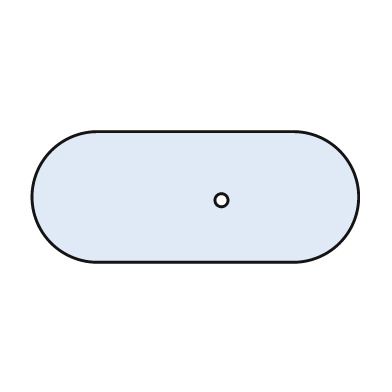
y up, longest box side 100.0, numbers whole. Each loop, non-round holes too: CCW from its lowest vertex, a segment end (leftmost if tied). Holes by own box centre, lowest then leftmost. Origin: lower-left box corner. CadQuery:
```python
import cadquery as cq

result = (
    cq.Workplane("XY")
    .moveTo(20.0, 0.0)
    .lineTo(80.0, 0.0)
    .threePointArc((100.0, 20.0), (80.0, 40.0))
    .lineTo(20.0, 40.0)
    .threePointArc((0.0, 20.0), (20.0, 0.0))
    .close()
    .moveTo(58.0, 19.0)
    .circle(2.0)
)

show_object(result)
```